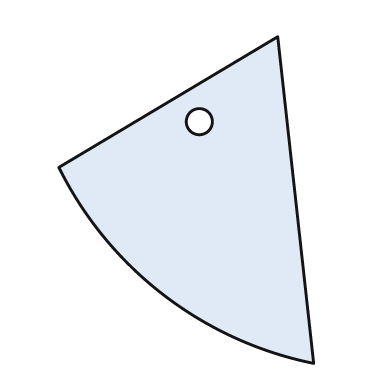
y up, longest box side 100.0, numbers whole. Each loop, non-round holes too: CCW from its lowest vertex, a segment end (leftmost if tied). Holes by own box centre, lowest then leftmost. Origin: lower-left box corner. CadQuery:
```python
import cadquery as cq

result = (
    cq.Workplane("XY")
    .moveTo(78.0, 0.0)
    .lineTo(67.0, 100.0)
    .lineTo(0.0, 60.0)
    .threePointArc((32.0, 21.0), (78.0, 0.0))
    .close()
    .moveTo(43.0, 74.0)
    .circle(4.0)
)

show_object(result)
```